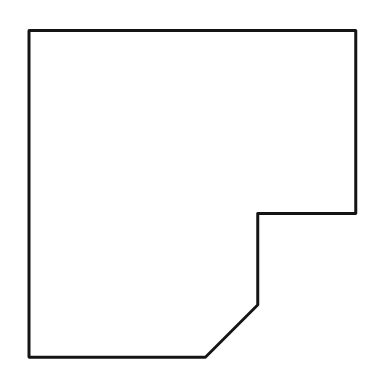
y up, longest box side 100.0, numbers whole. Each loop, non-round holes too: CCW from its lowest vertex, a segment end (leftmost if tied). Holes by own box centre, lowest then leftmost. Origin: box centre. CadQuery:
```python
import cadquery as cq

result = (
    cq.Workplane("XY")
    .moveTo(-50.0, -50.0)
    .lineTo(4.0, -50.0)
    .lineTo(20.0, -34.0)
    .lineTo(20.0, -6.0)
    .lineTo(50.0, -6.0)
    .lineTo(50.0, 50.0)
    .lineTo(-50.0, 50.0)
    .close()
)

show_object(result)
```